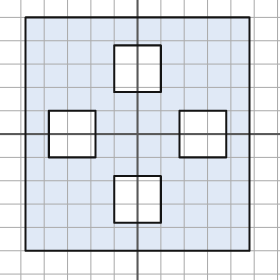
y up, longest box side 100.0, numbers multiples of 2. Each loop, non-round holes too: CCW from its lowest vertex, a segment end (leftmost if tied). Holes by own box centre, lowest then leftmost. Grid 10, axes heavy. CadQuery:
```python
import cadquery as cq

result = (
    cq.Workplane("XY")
    .moveTo(-48.0, -50.0)
    .lineTo(48.0, -50.0)
    .lineTo(48.0, 50.0)
    .lineTo(-48.0, 50.0)
    .close()
    .moveTo(-10.0, -38.0)
    .lineTo(10.0, -38.0)
    .lineTo(10.0, -18.0)
    .lineTo(-10.0, -18.0)
    .close()
    .moveTo(-38.0, -10.0)
    .lineTo(-18.0, -10.0)
    .lineTo(-18.0, 10.0)
    .lineTo(-38.0, 10.0)
    .close()
    .moveTo(18.0, -10.0)
    .lineTo(38.0, -10.0)
    .lineTo(38.0, 10.0)
    .lineTo(18.0, 10.0)
    .close()
    .moveTo(-10.0, 18.0)
    .lineTo(10.0, 18.0)
    .lineTo(10.0, 38.0)
    .lineTo(-10.0, 38.0)
    .close()
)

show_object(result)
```